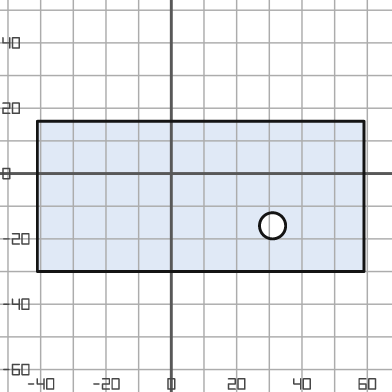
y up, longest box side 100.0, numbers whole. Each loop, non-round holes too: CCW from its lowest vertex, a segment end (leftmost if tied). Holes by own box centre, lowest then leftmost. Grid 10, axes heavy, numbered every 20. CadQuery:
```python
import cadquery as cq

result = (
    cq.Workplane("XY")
    .moveTo(-41.0, -30.0)
    .lineTo(59.0, -30.0)
    .lineTo(59.0, 16.0)
    .lineTo(-41.0, 16.0)
    .close()
    .moveTo(31.0, -16.0)
    .circle(4.0)
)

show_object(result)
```